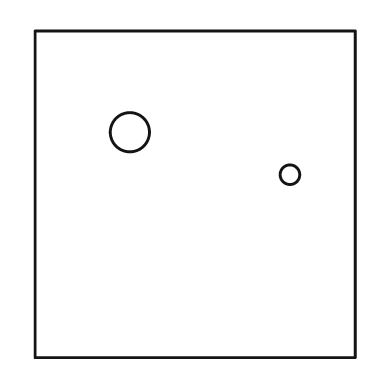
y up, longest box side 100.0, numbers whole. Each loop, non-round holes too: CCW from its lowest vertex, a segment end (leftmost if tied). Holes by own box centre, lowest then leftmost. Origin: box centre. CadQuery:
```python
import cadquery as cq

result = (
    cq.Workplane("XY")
    .moveTo(-49.0, -50.0)
    .lineTo(49.0, -50.0)
    .lineTo(49.0, 50.0)
    .lineTo(-49.0, 50.0)
    .close()
    .moveTo(29.0, 6.0)
    .circle(3.0)
    .moveTo(-20.0, 19.0)
    .circle(6.0)
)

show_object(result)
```